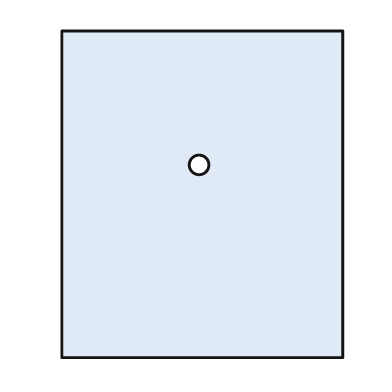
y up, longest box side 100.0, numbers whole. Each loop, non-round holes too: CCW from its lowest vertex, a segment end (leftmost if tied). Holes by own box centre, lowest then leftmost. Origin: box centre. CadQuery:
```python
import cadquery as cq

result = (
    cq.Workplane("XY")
    .moveTo(-43.0, -50.0)
    .lineTo(43.0, -50.0)
    .lineTo(43.0, 50.0)
    .lineTo(-43.0, 50.0)
    .close()
    .moveTo(-1.0, 9.0)
    .circle(3.0)
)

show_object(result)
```